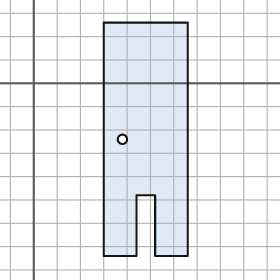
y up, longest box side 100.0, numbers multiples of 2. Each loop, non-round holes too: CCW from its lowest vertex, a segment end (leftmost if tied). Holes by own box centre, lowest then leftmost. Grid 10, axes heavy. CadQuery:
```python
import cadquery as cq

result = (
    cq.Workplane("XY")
    .moveTo(30.0, -74.0)
    .lineTo(44.0, -74.0)
    .lineTo(44.0, -48.0)
    .lineTo(52.0, -48.0)
    .lineTo(52.0, -74.0)
    .lineTo(66.0, -74.0)
    .lineTo(66.0, 26.0)
    .lineTo(30.0, 26.0)
    .close()
    .moveTo(38.0, -24.0)
    .circle(2.0)
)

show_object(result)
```